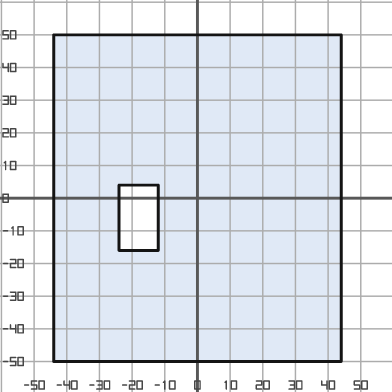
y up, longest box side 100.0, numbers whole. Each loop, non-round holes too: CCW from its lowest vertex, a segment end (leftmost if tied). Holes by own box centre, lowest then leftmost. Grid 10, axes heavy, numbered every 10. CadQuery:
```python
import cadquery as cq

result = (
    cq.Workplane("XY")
    .moveTo(-44.0, -50.0)
    .lineTo(44.0, -50.0)
    .lineTo(44.0, 50.0)
    .lineTo(-44.0, 50.0)
    .close()
    .moveTo(-24.0, -16.0)
    .lineTo(-12.0, -16.0)
    .lineTo(-12.0, 4.0)
    .lineTo(-24.0, 4.0)
    .close()
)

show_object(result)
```